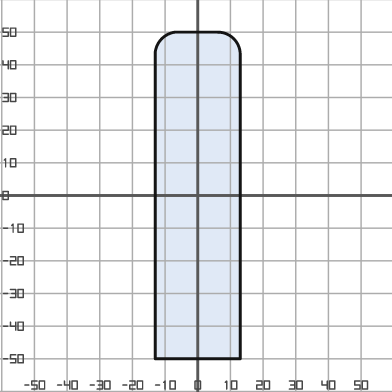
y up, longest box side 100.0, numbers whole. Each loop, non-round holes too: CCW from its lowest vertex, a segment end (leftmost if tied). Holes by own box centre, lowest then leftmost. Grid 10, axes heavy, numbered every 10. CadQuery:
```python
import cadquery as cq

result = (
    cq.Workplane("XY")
    .moveTo(-13.0, -50.0)
    .lineTo(13.0, -50.0)
    .lineTo(13.0, 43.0)
    .threePointArc((11.0, 48.0), (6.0, 50.0))
    .lineTo(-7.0, 50.0)
    .threePointArc((-11.0, 48.0), (-13.0, 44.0))
    .close()
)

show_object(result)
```